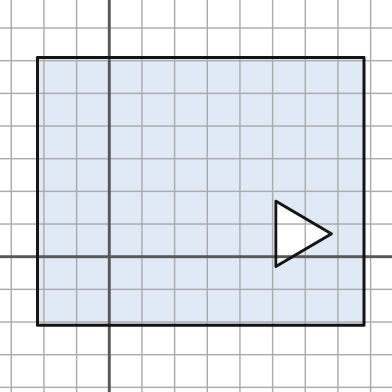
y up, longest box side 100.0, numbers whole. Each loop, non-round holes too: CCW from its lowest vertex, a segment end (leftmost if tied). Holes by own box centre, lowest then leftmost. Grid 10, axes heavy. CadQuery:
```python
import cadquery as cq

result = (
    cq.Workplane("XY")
    .moveTo(-22.0, -21.0)
    .lineTo(78.0, -21.0)
    .lineTo(78.0, 61.0)
    .lineTo(-22.0, 61.0)
    .close()
    .moveTo(51.0, -3.0)
    .lineTo(68.0, 7.0)
    .lineTo(51.0, 17.0)
    .close()
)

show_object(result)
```